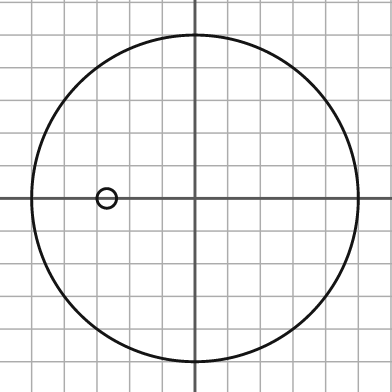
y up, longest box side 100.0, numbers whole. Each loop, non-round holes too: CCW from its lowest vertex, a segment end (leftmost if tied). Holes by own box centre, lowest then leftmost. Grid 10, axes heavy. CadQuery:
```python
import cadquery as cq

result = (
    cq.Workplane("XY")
    .moveTo(0.0, 0.0)
    .circle(50.0)
    .moveTo(-27.0, 0.0)
    .circle(3.0)
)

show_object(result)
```